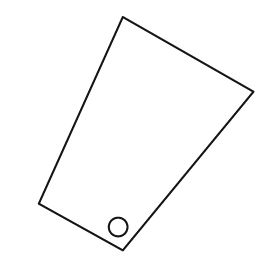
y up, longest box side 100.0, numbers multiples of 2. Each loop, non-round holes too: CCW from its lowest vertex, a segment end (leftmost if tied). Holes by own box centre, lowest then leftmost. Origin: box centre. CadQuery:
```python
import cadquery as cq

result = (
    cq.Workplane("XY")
    .moveTo(-10.0, -50.0)
    .lineTo(46.0, 18.0)
    .lineTo(-10.0, 50.0)
    .lineTo(-46.0, -30.0)
    .close()
    .moveTo(-12.0, -40.0)
    .circle(4.0)
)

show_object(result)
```